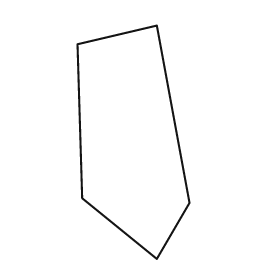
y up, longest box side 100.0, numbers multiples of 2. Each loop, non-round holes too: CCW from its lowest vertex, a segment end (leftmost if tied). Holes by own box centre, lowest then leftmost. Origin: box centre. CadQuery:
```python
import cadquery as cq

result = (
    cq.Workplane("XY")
    .moveTo(10.0, -50.0)
    .lineTo(24.0, -26.0)
    .lineTo(10.0, 50.0)
    .lineTo(-24.0, 42.0)
    .lineTo(-22.0, -24.0)
    .close()
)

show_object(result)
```